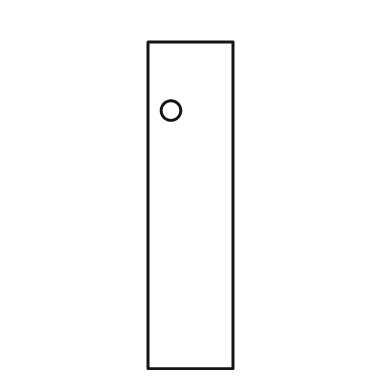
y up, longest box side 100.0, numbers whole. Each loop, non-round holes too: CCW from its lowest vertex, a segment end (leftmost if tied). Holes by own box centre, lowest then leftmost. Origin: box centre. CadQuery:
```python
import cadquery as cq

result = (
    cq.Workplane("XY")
    .moveTo(-13.0, -50.0)
    .lineTo(13.0, -50.0)
    .lineTo(13.0, 50.0)
    .lineTo(-13.0, 50.0)
    .close()
    .moveTo(-6.0, 29.0)
    .circle(3.0)
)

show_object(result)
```